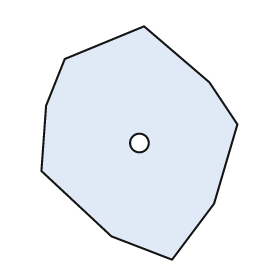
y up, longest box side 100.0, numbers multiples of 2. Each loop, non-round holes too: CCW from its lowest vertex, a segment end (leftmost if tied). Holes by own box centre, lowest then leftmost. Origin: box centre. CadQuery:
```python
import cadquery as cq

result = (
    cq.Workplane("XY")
    .moveTo(14.0, -50.0)
    .lineTo(32.0, -26.0)
    .lineTo(42.0, 8.0)
    .lineTo(30.0, 26.0)
    .lineTo(2.0, 50.0)
    .lineTo(-32.0, 36.0)
    .lineTo(-40.0, 16.0)
    .lineTo(-42.0, -12.0)
    .lineTo(-12.0, -40.0)
    .close()
    .moveTo(0.0, 0.0)
    .circle(4.0)
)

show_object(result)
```